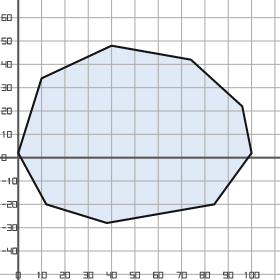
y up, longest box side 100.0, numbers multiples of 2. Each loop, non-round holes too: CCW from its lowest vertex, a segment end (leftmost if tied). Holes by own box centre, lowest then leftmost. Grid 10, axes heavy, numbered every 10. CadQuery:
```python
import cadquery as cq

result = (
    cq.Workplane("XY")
    .moveTo(38.0, -28.0)
    .lineTo(84.0, -20.0)
    .lineTo(100.0, 2.0)
    .lineTo(96.0, 22.0)
    .lineTo(74.0, 42.0)
    .lineTo(40.0, 48.0)
    .lineTo(10.0, 34.0)
    .lineTo(0.0, 2.0)
    .lineTo(12.0, -20.0)
    .close()
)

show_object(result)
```